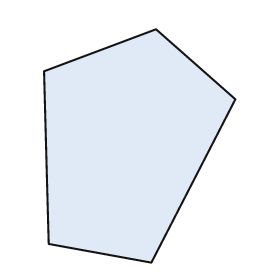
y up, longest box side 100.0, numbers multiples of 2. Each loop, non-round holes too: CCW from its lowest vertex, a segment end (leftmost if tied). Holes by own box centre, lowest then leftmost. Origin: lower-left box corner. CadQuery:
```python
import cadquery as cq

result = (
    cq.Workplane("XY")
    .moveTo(46.0, 0.0)
    .lineTo(82.0, 70.0)
    .lineTo(48.0, 100.0)
    .lineTo(0.0, 82.0)
    .lineTo(2.0, 8.0)
    .close()
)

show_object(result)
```